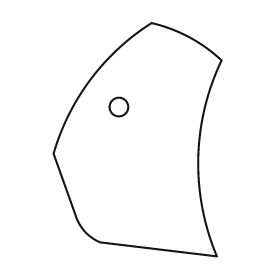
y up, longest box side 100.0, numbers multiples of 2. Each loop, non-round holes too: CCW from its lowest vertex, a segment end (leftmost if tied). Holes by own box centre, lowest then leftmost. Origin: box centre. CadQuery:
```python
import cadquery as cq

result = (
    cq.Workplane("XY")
    .moveTo(34.0, -50.0)
    .threePointArc((26.0, -8.0), (36.0, 34.0))
    .threePointArc((22.0, 44.0), (6.0, 50.0))
    .threePointArc((-20.0, 26.0), (-36.0, -6.0))
    .lineTo(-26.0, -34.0)
    .threePointArc((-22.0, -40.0), (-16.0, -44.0))
    .close()
    .moveTo(-8.0, 14.0)
    .circle(4.0)
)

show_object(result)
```